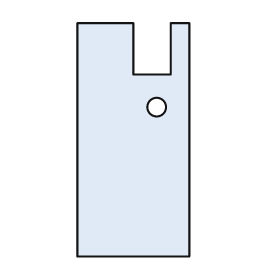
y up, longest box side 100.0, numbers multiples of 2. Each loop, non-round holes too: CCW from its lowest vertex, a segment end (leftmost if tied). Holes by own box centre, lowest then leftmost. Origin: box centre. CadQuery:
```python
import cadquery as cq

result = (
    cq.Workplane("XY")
    .moveTo(-24.0, -50.0)
    .lineTo(24.0, -50.0)
    .lineTo(24.0, 50.0)
    .lineTo(16.0, 50.0)
    .lineTo(16.0, 28.0)
    .lineTo(0.0, 28.0)
    .lineTo(0.0, 50.0)
    .lineTo(-24.0, 50.0)
    .close()
    .moveTo(10.0, 14.0)
    .circle(4.0)
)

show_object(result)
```